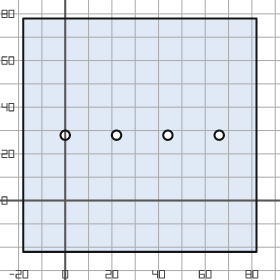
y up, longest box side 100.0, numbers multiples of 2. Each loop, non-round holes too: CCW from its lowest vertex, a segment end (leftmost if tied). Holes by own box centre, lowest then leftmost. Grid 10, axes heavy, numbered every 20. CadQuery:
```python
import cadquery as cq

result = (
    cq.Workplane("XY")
    .moveTo(-18.0, -22.0)
    .lineTo(82.0, -22.0)
    .lineTo(82.0, 78.0)
    .lineTo(-18.0, 78.0)
    .close()
    .moveTo(0.0, 28.0)
    .circle(2.0)
    .moveTo(22.0, 28.0)
    .circle(2.0)
    .moveTo(44.0, 28.0)
    .circle(2.0)
    .moveTo(66.0, 28.0)
    .circle(2.0)
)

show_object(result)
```